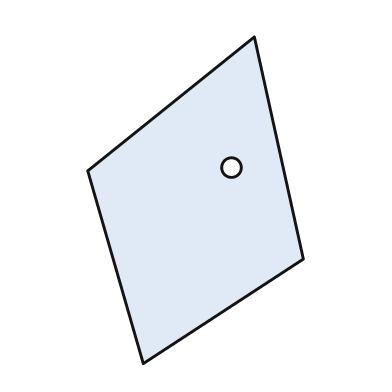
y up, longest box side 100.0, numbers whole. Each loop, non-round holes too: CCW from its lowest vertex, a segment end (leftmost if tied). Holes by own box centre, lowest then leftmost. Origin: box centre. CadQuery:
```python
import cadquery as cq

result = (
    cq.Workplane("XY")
    .moveTo(-16.0, -50.0)
    .lineTo(33.0, -18.0)
    .lineTo(18.0, 50.0)
    .lineTo(-33.0, 9.0)
    .close()
    .moveTo(11.0, 10.0)
    .circle(3.0)
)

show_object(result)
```